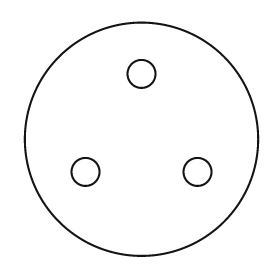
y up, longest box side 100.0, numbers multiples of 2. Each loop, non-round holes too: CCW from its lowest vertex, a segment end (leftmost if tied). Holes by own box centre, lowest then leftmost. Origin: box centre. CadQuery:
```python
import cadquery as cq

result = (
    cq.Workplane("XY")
    .moveTo(0.0, 0.0)
    .circle(50.0)
    .moveTo(-24.0, -14.0)
    .circle(6.0)
    .moveTo(24.0, -14.0)
    .circle(6.0)
    .moveTo(0.0, 28.0)
    .circle(6.0)
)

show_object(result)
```